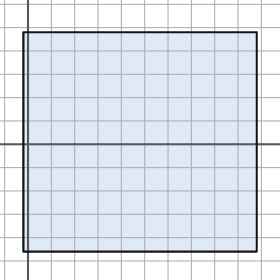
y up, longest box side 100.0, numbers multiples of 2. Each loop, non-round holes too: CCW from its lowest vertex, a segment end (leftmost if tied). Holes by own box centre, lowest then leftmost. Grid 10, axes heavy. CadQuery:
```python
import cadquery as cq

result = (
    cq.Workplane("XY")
    .moveTo(-2.0, -46.0)
    .lineTo(98.0, -46.0)
    .lineTo(98.0, 48.0)
    .lineTo(-2.0, 48.0)
    .close()
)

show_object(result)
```